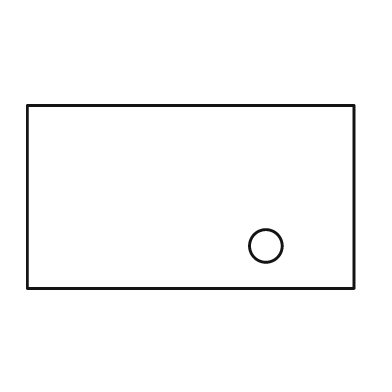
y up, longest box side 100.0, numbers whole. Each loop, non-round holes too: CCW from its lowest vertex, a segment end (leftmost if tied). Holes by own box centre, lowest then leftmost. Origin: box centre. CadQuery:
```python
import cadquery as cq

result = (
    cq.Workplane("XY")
    .moveTo(-50.0, -28.0)
    .lineTo(50.0, -28.0)
    .lineTo(50.0, 28.0)
    .lineTo(-50.0, 28.0)
    .close()
    .moveTo(23.0, -15.0)
    .circle(5.0)
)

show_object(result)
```